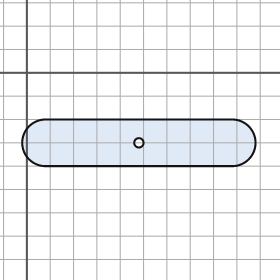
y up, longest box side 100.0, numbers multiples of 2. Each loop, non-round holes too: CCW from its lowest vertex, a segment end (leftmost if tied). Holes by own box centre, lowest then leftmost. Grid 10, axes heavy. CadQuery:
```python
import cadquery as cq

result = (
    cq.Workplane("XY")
    .moveTo(8.0, -40.0)
    .lineTo(88.0, -40.0)
    .threePointArc((98.0, -30.0), (88.0, -20.0))
    .lineTo(8.0, -20.0)
    .threePointArc((-2.0, -30.0), (8.0, -40.0))
    .close()
    .moveTo(48.0, -30.0)
    .circle(2.0)
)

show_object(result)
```